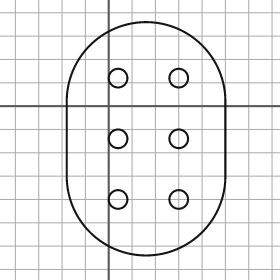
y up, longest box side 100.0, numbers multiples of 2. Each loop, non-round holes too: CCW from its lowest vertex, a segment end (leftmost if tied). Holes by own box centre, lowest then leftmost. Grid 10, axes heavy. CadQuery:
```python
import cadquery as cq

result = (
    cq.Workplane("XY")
    .moveTo(-18.0, -30.0)
    .threePointArc((16.0, -64.0), (50.0, -30.0))
    .lineTo(50.0, 2.0)
    .threePointArc((16.0, 36.0), (-18.0, 2.0))
    .close()
    .moveTo(4.0, -40.0)
    .circle(4.0)
    .moveTo(30.0, -40.0)
    .circle(4.0)
    .moveTo(4.0, -14.0)
    .circle(4.0)
    .moveTo(30.0, -14.0)
    .circle(4.0)
    .moveTo(4.0, 12.0)
    .circle(4.0)
    .moveTo(30.0, 12.0)
    .circle(4.0)
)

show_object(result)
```